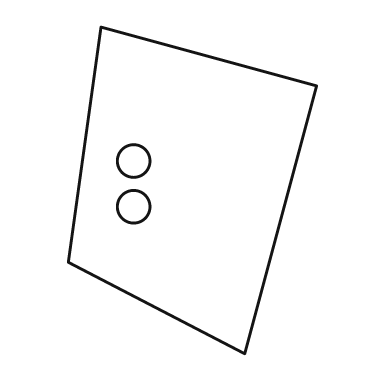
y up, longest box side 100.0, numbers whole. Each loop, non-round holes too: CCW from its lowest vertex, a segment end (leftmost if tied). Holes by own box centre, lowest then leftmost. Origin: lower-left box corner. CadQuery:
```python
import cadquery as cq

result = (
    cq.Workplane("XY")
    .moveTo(54.0, 0.0)
    .lineTo(76.0, 82.0)
    .lineTo(10.0, 100.0)
    .lineTo(0.0, 28.0)
    .close()
    .moveTo(20.0, 45.0)
    .circle(5.0)
    .moveTo(20.0, 59.0)
    .circle(5.0)
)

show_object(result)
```